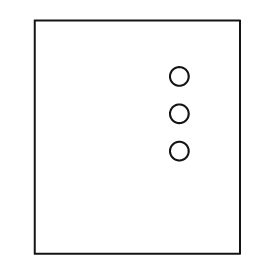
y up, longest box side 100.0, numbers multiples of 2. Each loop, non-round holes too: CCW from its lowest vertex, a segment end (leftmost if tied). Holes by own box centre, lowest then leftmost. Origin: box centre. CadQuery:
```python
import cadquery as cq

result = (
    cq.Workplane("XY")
    .moveTo(-44.0, -50.0)
    .lineTo(44.0, -50.0)
    .lineTo(44.0, 50.0)
    .lineTo(-44.0, 50.0)
    .close()
    .moveTo(18.0, -6.0)
    .circle(4.0)
    .moveTo(18.0, 10.0)
    .circle(4.0)
    .moveTo(18.0, 26.0)
    .circle(4.0)
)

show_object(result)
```